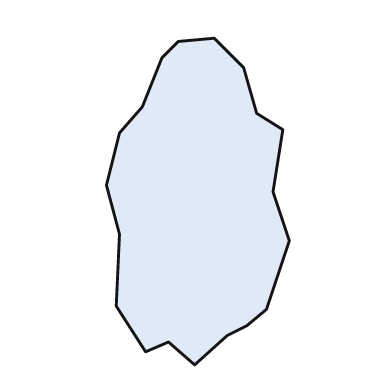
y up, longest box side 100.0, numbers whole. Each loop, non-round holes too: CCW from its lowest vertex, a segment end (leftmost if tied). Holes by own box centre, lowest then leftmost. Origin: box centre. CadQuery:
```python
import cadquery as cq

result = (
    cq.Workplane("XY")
    .moveTo(-1.0, -50.0)
    .lineTo(9.0, -41.0)
    .lineTo(15.0, -38.0)
    .lineTo(21.0, -33.0)
    .lineTo(28.0, -12.0)
    .lineTo(23.0, 3.0)
    .lineTo(26.0, 22.0)
    .lineTo(18.0, 27.0)
    .lineTo(14.0, 41.0)
    .lineTo(5.0, 50.0)
    .lineTo(-6.0, 49.0)
    .lineTo(-11.0, 44.0)
    .lineTo(-17.0, 29.0)
    .lineTo(-24.0, 21.0)
    .lineTo(-28.0, 5.0)
    .lineTo(-24.0, -10.0)
    .lineTo(-25.0, -32.0)
    .lineTo(-16.0, -46.0)
    .lineTo(-9.0, -43.0)
    .close()
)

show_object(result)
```